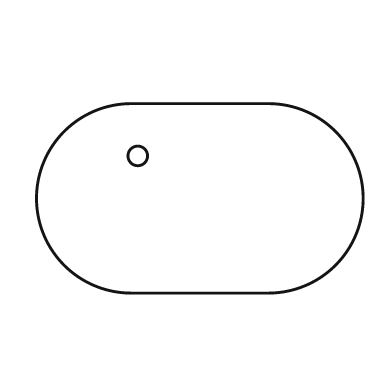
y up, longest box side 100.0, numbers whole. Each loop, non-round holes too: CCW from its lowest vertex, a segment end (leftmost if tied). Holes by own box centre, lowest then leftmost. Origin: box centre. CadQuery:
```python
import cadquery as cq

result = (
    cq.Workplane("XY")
    .moveTo(-21.0, -29.0)
    .lineTo(21.0, -29.0)
    .threePointArc((50.0, 0.0), (21.0, 29.0))
    .lineTo(-21.0, 29.0)
    .threePointArc((-50.0, 0.0), (-21.0, -29.0))
    .close()
    .moveTo(-19.0, 13.0)
    .circle(3.0)
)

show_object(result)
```